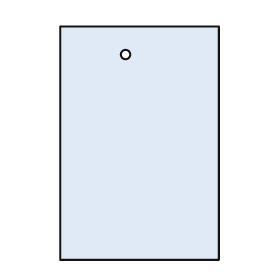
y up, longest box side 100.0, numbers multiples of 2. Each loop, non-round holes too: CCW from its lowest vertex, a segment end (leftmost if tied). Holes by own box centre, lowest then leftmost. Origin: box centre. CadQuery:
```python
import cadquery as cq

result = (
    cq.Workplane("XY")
    .moveTo(-34.0, -50.0)
    .lineTo(34.0, -50.0)
    .lineTo(34.0, 50.0)
    .lineTo(-34.0, 50.0)
    .close()
    .moveTo(-6.0, 38.0)
    .circle(2.0)
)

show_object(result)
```